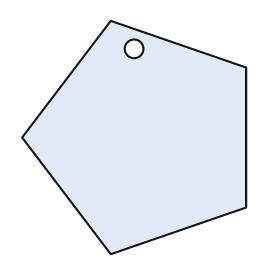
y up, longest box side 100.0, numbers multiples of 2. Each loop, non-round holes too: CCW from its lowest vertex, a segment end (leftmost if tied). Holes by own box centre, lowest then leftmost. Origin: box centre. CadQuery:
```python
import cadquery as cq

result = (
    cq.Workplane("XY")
    .moveTo(-10.0, -50.0)
    .lineTo(48.0, -30.0)
    .lineTo(48.0, 30.0)
    .lineTo(-10.0, 50.0)
    .lineTo(-48.0, 0.0)
    .close()
    .moveTo(0.0, 38.0)
    .circle(4.0)
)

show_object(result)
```